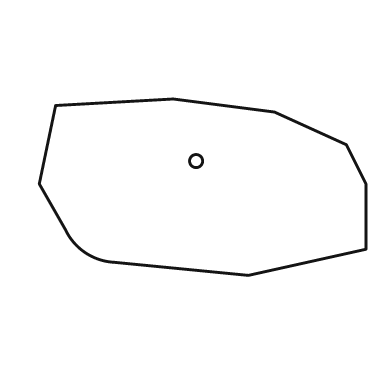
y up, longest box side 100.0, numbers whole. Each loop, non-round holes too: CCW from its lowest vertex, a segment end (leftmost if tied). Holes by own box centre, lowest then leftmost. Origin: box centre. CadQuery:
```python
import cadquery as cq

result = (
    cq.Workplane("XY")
    .moveTo(14.0, -27.0)
    .lineTo(50.0, -19.0)
    .lineTo(50.0, 1.0)
    .lineTo(44.0, 13.0)
    .lineTo(22.0, 23.0)
    .lineTo(-9.0, 27.0)
    .lineTo(-45.0, 25.0)
    .lineTo(-50.0, 1.0)
    .lineTo(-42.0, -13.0)
    .threePointArc((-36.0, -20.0), (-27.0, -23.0))
    .close()
    .moveTo(-2.0, 8.0)
    .circle(2.0)
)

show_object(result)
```